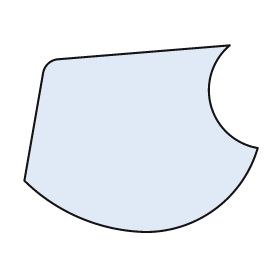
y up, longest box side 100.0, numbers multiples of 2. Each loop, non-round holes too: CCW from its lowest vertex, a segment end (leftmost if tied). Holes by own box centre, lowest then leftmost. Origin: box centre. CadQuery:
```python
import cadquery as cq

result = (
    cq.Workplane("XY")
    .moveTo(2.0, -40.0)
    .threePointArc((32.0, -30.0), (50.0, -4.0))
    .threePointArc((30.0, 14.0), (38.0, 40.0))
    .lineTo(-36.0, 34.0)
    .threePointArc((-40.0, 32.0), (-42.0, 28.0))
    .lineTo(-50.0, -18.0)
    .threePointArc((-26.0, -34.0), (2.0, -40.0))
    .close()
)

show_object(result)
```